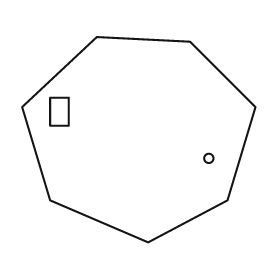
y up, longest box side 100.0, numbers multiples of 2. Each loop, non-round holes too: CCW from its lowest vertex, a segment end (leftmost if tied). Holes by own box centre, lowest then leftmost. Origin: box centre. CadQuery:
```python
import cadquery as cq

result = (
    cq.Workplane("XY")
    .moveTo(4.0, -44.0)
    .lineTo(38.0, -26.0)
    .lineTo(50.0, 14.0)
    .lineTo(22.0, 42.0)
    .lineTo(-18.0, 44.0)
    .lineTo(-50.0, 14.0)
    .lineTo(-38.0, -26.0)
    .close()
    .moveTo(30.0, -8.0)
    .circle(2.0)
    .moveTo(-38.0, 6.0)
    .lineTo(-30.0, 6.0)
    .lineTo(-30.0, 18.0)
    .lineTo(-38.0, 18.0)
    .close()
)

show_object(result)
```